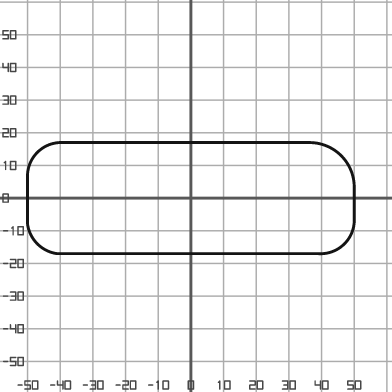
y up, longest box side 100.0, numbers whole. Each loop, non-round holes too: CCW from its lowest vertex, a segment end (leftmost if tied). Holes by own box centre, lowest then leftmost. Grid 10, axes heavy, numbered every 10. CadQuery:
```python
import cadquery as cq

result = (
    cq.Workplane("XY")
    .moveTo(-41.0, -17.0)
    .lineTo(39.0, -17.0)
    .threePointArc((47.0, -14.0), (50.0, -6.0))
    .lineTo(50.0, 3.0)
    .threePointArc((46.0, 13.0), (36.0, 17.0))
    .lineTo(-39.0, 17.0)
    .threePointArc((-47.0, 14.0), (-50.0, 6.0))
    .lineTo(-50.0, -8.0)
    .threePointArc((-47.0, -14.0), (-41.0, -17.0))
    .close()
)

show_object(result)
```